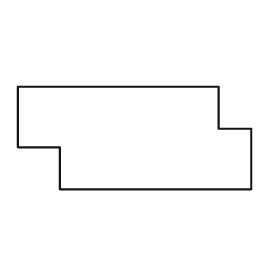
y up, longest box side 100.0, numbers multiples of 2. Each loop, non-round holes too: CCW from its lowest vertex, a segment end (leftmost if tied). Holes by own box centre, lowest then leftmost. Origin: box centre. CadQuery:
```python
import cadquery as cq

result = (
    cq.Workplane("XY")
    .moveTo(-32.0, -22.0)
    .lineTo(50.0, -22.0)
    .lineTo(50.0, 4.0)
    .lineTo(36.0, 4.0)
    .lineTo(36.0, 22.0)
    .lineTo(-50.0, 22.0)
    .lineTo(-50.0, -4.0)
    .lineTo(-32.0, -4.0)
    .close()
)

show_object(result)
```